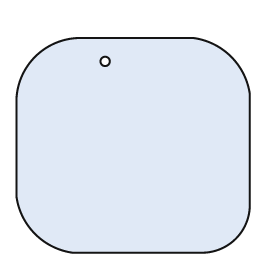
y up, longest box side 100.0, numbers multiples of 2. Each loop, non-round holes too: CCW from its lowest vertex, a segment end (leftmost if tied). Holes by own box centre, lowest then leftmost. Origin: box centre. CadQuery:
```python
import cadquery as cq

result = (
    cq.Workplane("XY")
    .moveTo(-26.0, -46.0)
    .lineTo(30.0, -46.0)
    .threePointArc((44.0, -40.0), (50.0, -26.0))
    .lineTo(50.0, 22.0)
    .threePointArc((42.0, 38.0), (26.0, 46.0))
    .lineTo(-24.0, 46.0)
    .threePointArc((-42.0, 38.0), (-50.0, 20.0))
    .lineTo(-50.0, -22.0)
    .threePointArc((-42.0, -38.0), (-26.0, -46.0))
    .close()
    .moveTo(-12.0, 36.0)
    .circle(2.0)
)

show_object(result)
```